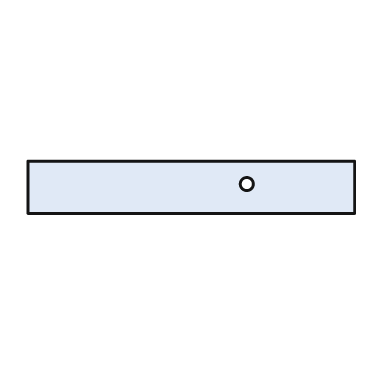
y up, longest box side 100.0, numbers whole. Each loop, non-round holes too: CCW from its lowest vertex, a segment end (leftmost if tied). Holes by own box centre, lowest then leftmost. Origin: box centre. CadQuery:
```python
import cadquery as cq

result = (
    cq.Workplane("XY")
    .moveTo(-50.0, -8.0)
    .lineTo(50.0, -8.0)
    .lineTo(50.0, 8.0)
    .lineTo(-50.0, 8.0)
    .close()
    .moveTo(17.0, 1.0)
    .circle(2.0)
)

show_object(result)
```